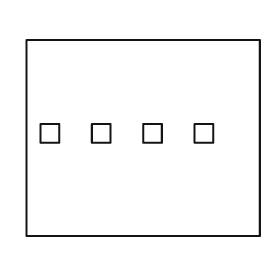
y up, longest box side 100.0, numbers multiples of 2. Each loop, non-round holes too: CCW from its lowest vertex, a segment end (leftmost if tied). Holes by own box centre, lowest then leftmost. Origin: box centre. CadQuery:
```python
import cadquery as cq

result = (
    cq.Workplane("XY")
    .moveTo(-50.0, -42.0)
    .lineTo(50.0, -42.0)
    .lineTo(50.0, 42.0)
    .lineTo(-50.0, 42.0)
    .close()
    .moveTo(-44.0, -2.0)
    .lineTo(-36.0, -2.0)
    .lineTo(-36.0, 6.0)
    .lineTo(-44.0, 6.0)
    .close()
    .moveTo(-22.0, -2.0)
    .lineTo(-14.0, -2.0)
    .lineTo(-14.0, 6.0)
    .lineTo(-22.0, 6.0)
    .close()
    .moveTo(0.0, -2.0)
    .lineTo(8.0, -2.0)
    .lineTo(8.0, 6.0)
    .lineTo(0.0, 6.0)
    .close()
    .moveTo(22.0, -2.0)
    .lineTo(30.0, -2.0)
    .lineTo(30.0, 6.0)
    .lineTo(22.0, 6.0)
    .close()
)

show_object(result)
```